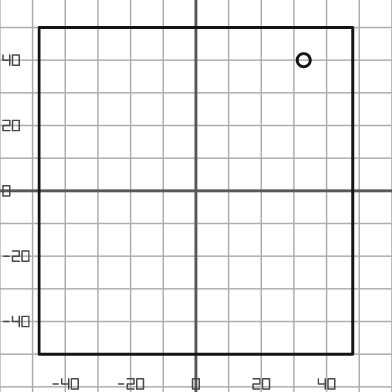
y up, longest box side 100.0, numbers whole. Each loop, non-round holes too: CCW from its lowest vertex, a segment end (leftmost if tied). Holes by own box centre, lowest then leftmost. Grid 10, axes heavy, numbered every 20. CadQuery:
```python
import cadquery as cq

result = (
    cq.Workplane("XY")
    .moveTo(-48.0, -50.0)
    .lineTo(48.0, -50.0)
    .lineTo(48.0, 50.0)
    .lineTo(-48.0, 50.0)
    .close()
    .moveTo(33.0, 40.0)
    .circle(2.0)
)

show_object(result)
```